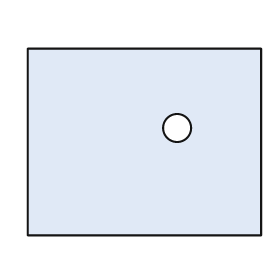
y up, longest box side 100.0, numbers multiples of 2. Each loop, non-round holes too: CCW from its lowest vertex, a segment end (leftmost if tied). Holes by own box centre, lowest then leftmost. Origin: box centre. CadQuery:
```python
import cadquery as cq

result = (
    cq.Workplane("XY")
    .moveTo(-50.0, -40.0)
    .lineTo(50.0, -40.0)
    .lineTo(50.0, 40.0)
    .lineTo(-50.0, 40.0)
    .close()
    .moveTo(14.0, 6.0)
    .circle(6.0)
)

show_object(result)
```